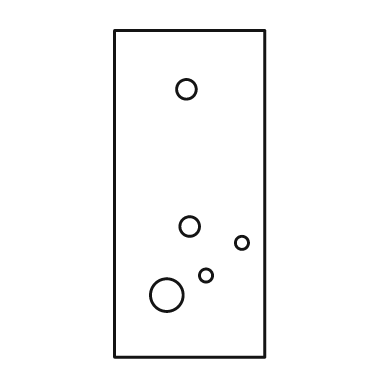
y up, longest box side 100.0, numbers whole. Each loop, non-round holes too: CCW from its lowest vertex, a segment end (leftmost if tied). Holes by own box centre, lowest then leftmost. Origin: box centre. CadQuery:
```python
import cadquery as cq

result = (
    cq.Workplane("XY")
    .moveTo(-23.0, -50.0)
    .lineTo(23.0, -50.0)
    .lineTo(23.0, 50.0)
    .lineTo(-23.0, 50.0)
    .close()
    .moveTo(-7.0, -31.0)
    .circle(5.0)
    .moveTo(5.0, -25.0)
    .circle(2.0)
    .moveTo(16.0, -15.0)
    .circle(2.0)
    .moveTo(0.0, -10.0)
    .circle(3.0)
    .moveTo(-1.0, 32.0)
    .circle(3.0)
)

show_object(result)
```